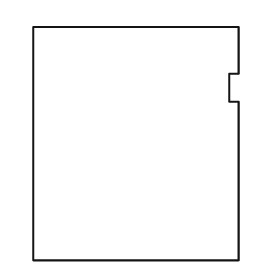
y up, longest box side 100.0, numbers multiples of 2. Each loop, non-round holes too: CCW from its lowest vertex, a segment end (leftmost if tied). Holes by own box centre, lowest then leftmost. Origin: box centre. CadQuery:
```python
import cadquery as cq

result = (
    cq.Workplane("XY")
    .moveTo(-44.0, -50.0)
    .lineTo(44.0, -50.0)
    .lineTo(44.0, 18.0)
    .lineTo(40.0, 18.0)
    .lineTo(40.0, 30.0)
    .lineTo(44.0, 30.0)
    .lineTo(44.0, 50.0)
    .lineTo(-44.0, 50.0)
    .close()
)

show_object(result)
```